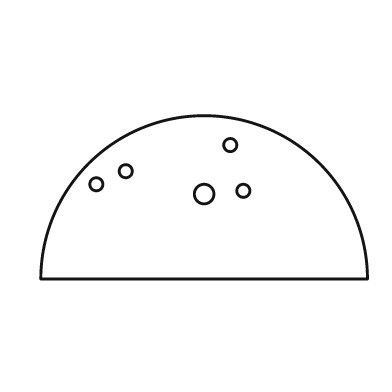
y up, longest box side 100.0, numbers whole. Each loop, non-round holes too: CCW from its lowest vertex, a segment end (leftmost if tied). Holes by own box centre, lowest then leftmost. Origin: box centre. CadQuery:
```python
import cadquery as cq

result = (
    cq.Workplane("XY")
    .moveTo(-50.0, -25.0)
    .lineTo(50.0, -25.0)
    .threePointArc((0.0, 25.0), (-50.0, -25.0))
    .close()
    .moveTo(0.0, 1.0)
    .circle(3.0)
    .moveTo(12.0, 2.0)
    .circle(2.0)
    .moveTo(-33.0, 4.0)
    .circle(2.0)
    .moveTo(-24.0, 8.0)
    .circle(2.0)
    .moveTo(8.0, 16.0)
    .circle(2.0)
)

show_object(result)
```